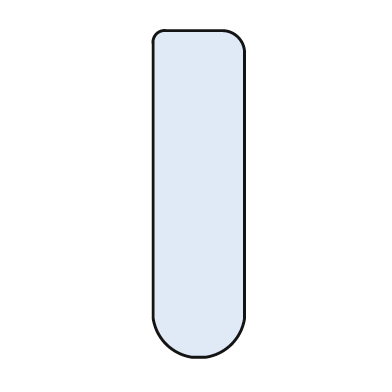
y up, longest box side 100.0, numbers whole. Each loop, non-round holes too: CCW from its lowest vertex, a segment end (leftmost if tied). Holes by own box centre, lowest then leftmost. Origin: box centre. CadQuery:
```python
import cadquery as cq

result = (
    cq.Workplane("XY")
    .moveTo(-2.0, -50.0)
    .lineTo(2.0, -50.0)
    .threePointArc((10.0, -46.0), (14.0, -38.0))
    .lineTo(14.0, 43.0)
    .threePointArc((12.0, 48.0), (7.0, 50.0))
    .lineTo(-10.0, 50.0)
    .threePointArc((-13.0, 49.0), (-14.0, 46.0))
    .lineTo(-14.0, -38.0)
    .threePointArc((-10.0, -46.0), (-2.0, -50.0))
    .close()
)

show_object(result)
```